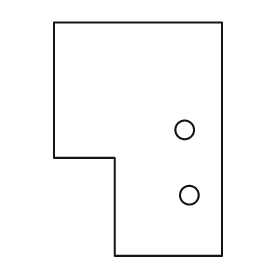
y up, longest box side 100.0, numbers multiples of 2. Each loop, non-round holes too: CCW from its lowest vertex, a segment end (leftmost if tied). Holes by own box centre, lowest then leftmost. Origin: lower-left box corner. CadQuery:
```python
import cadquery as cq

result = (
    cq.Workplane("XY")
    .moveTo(26.0, 0.0)
    .lineTo(72.0, 0.0)
    .lineTo(72.0, 100.0)
    .lineTo(0.0, 100.0)
    .lineTo(0.0, 42.0)
    .lineTo(26.0, 42.0)
    .close()
    .moveTo(58.0, 26.0)
    .circle(4.0)
    .moveTo(56.0, 54.0)
    .circle(4.0)
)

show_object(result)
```